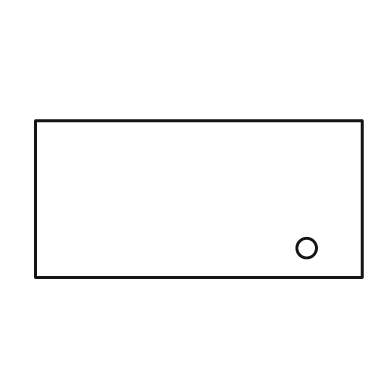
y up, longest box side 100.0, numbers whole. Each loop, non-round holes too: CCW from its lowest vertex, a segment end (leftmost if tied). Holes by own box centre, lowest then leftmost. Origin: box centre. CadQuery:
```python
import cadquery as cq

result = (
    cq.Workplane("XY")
    .moveTo(-50.0, -24.0)
    .lineTo(50.0, -24.0)
    .lineTo(50.0, 24.0)
    .lineTo(-50.0, 24.0)
    .close()
    .moveTo(33.0, -15.0)
    .circle(3.0)
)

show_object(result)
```